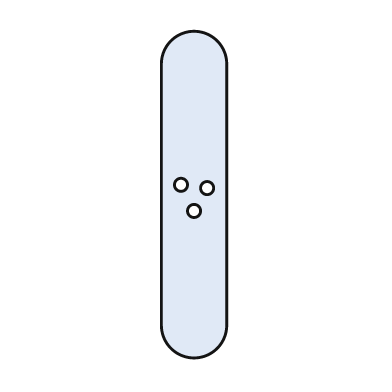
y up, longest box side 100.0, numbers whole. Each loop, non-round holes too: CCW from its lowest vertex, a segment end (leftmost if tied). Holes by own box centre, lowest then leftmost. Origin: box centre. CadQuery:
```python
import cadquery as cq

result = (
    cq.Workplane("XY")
    .moveTo(-10.0, -40.0)
    .threePointArc((0.0, -50.0), (10.0, -40.0))
    .lineTo(10.0, 40.0)
    .threePointArc((0.0, 50.0), (-10.0, 40.0))
    .close()
    .moveTo(0.0, -5.0)
    .circle(2.0)
    .moveTo(4.0, 2.0)
    .circle(2.0)
    .moveTo(-4.0, 3.0)
    .circle(2.0)
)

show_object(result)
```